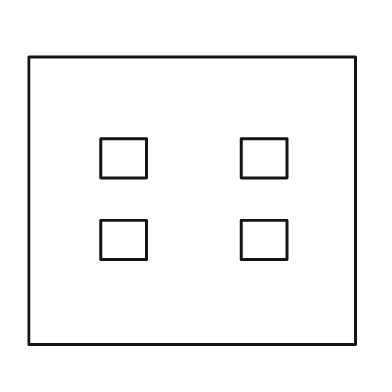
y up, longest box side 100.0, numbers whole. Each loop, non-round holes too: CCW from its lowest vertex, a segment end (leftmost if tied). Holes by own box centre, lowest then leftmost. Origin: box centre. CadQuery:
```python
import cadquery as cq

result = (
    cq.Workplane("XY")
    .moveTo(-50.0, -44.0)
    .lineTo(50.0, -44.0)
    .lineTo(50.0, 44.0)
    .lineTo(-50.0, 44.0)
    .close()
    .moveTo(-28.0, -18.0)
    .lineTo(-14.0, -18.0)
    .lineTo(-14.0, -6.0)
    .lineTo(-28.0, -6.0)
    .close()
    .moveTo(15.0, -18.0)
    .lineTo(29.0, -18.0)
    .lineTo(29.0, -6.0)
    .lineTo(15.0, -6.0)
    .close()
    .moveTo(-28.0, 7.0)
    .lineTo(-14.0, 7.0)
    .lineTo(-14.0, 19.0)
    .lineTo(-28.0, 19.0)
    .close()
    .moveTo(15.0, 7.0)
    .lineTo(29.0, 7.0)
    .lineTo(29.0, 19.0)
    .lineTo(15.0, 19.0)
    .close()
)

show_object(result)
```